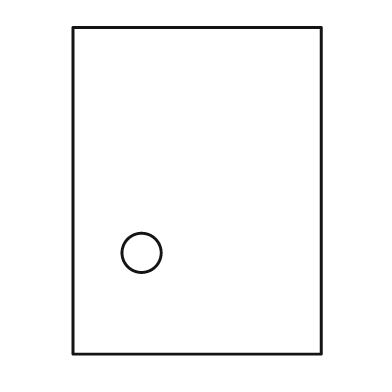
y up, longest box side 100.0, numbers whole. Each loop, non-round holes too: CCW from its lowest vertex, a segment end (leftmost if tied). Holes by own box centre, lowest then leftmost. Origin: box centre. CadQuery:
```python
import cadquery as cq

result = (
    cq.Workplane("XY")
    .moveTo(-38.0, -50.0)
    .lineTo(38.0, -50.0)
    .lineTo(38.0, 50.0)
    .lineTo(-38.0, 50.0)
    .close()
    .moveTo(-17.0, -19.0)
    .circle(6.0)
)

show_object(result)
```